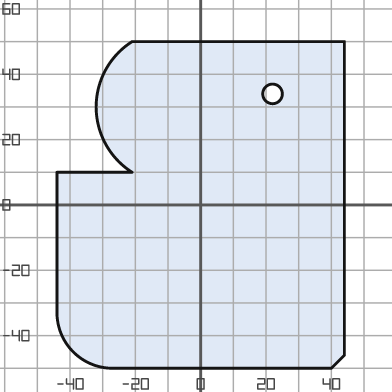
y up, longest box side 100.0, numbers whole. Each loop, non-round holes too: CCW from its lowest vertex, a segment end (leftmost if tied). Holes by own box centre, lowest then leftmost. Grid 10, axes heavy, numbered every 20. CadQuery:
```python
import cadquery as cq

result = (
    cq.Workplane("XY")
    .moveTo(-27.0, -50.0)
    .lineTo(40.0, -50.0)
    .lineTo(44.0, -46.0)
    .lineTo(44.0, 50.0)
    .lineTo(-21.0, 50.0)
    .threePointArc((-32.0, 30.0), (-21.0, 10.0))
    .lineTo(-44.0, 10.0)
    .lineTo(-44.0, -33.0)
    .threePointArc((-39.0, -45.0), (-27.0, -50.0))
    .close()
    .moveTo(22.0, 34.0)
    .circle(3.0)
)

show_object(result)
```